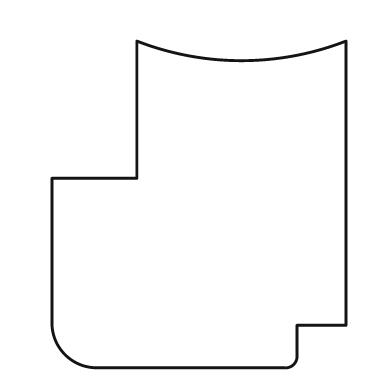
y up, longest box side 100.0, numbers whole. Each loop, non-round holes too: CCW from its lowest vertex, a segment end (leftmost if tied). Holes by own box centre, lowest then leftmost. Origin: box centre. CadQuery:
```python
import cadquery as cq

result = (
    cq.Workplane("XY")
    .moveTo(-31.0, -50.0)
    .lineTo(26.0, -50.0)
    .threePointArc((29.0, -49.0), (30.0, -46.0))
    .lineTo(30.0, -37.0)
    .lineTo(45.0, -37.0)
    .lineTo(45.0, 50.0)
    .threePointArc((13.0, 44.0), (-19.0, 50.0))
    .lineTo(-19.0, 8.0)
    .lineTo(-45.0, 8.0)
    .lineTo(-45.0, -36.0)
    .threePointArc((-41.0, -46.0), (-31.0, -50.0))
    .close()
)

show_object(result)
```